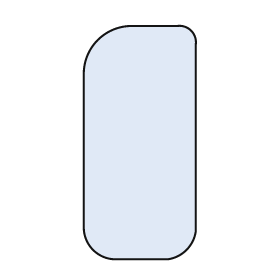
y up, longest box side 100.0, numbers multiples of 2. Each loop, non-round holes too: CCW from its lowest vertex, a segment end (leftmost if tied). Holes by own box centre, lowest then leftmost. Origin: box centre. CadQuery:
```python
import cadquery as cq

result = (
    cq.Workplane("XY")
    .moveTo(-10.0, -50.0)
    .lineTo(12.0, -50.0)
    .threePointArc((20.0, -46.0), (24.0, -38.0))
    .lineTo(24.0, 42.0)
    .threePointArc((22.0, 48.0), (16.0, 50.0))
    .lineTo(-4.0, 50.0)
    .threePointArc((-18.0, 44.0), (-24.0, 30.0))
    .lineTo(-24.0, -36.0)
    .threePointArc((-20.0, -46.0), (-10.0, -50.0))
    .close()
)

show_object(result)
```